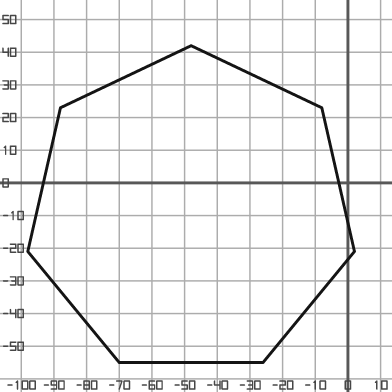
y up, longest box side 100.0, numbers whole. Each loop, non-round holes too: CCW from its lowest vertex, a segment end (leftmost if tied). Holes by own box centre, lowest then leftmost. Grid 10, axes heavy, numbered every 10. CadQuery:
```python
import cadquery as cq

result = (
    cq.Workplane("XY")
    .moveTo(-70.0, -55.0)
    .lineTo(-26.0, -55.0)
    .lineTo(2.0, -21.0)
    .lineTo(-8.0, 23.0)
    .lineTo(-48.0, 42.0)
    .lineTo(-88.0, 23.0)
    .lineTo(-98.0, -21.0)
    .close()
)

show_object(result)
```